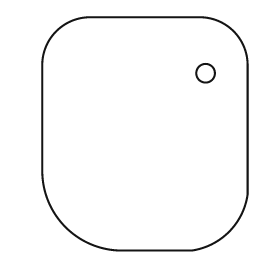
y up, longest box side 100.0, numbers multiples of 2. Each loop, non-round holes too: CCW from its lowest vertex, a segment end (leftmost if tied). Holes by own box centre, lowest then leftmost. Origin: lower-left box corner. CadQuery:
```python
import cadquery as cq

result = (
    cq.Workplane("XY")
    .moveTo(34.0, 0.0)
    .lineTo(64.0, 0.0)
    .threePointArc((80.0, 8.0), (88.0, 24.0))
    .lineTo(88.0, 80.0)
    .threePointArc((82.0, 94.0), (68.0, 100.0))
    .lineTo(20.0, 100.0)
    .threePointArc((6.0, 94.0), (0.0, 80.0))
    .lineTo(0.0, 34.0)
    .threePointArc((10.0, 10.0), (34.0, 0.0))
    .close()
    .moveTo(70.0, 76.0)
    .circle(4.0)
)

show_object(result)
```